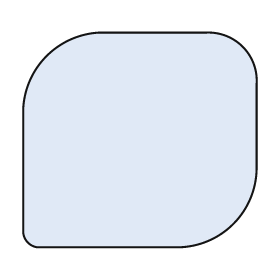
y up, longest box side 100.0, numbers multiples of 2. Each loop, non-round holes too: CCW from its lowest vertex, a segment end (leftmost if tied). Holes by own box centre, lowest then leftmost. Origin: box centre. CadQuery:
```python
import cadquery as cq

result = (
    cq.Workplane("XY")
    .moveTo(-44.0, -46.0)
    .lineTo(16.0, -46.0)
    .threePointArc((40.0, -36.0), (50.0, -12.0))
    .lineTo(50.0, 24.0)
    .threePointArc((44.0, 40.0), (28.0, 46.0))
    .lineTo(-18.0, 46.0)
    .threePointArc((-40.0, 36.0), (-50.0, 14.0))
    .lineTo(-50.0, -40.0)
    .threePointArc((-48.0, -44.0), (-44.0, -46.0))
    .close()
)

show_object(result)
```